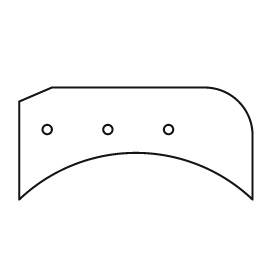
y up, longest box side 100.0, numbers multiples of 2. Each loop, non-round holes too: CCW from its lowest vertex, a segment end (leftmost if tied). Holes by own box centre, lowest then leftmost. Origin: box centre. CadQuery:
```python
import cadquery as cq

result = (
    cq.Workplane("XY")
    .moveTo(-50.0, -24.0)
    .threePointArc((0.0, -4.0), (50.0, -24.0))
    .lineTo(50.0, 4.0)
    .threePointArc((44.0, 18.0), (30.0, 24.0))
    .lineTo(-36.0, 24.0)
    .lineTo(-50.0, 18.0)
    .close()
    .moveTo(-38.0, 6.0)
    .circle(2.0)
    .moveTo(-12.0, 6.0)
    .circle(2.0)
    .moveTo(14.0, 6.0)
    .circle(2.0)
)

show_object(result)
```